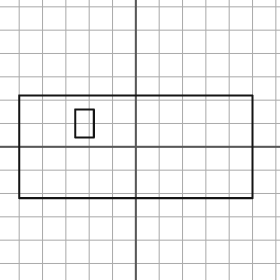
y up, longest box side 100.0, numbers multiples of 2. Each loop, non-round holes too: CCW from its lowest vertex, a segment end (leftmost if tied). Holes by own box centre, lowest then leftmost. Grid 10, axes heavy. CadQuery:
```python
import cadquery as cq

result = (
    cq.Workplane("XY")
    .moveTo(-50.0, -22.0)
    .lineTo(50.0, -22.0)
    .lineTo(50.0, 22.0)
    .lineTo(-50.0, 22.0)
    .close()
    .moveTo(-26.0, 4.0)
    .lineTo(-18.0, 4.0)
    .lineTo(-18.0, 16.0)
    .lineTo(-26.0, 16.0)
    .close()
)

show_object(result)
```